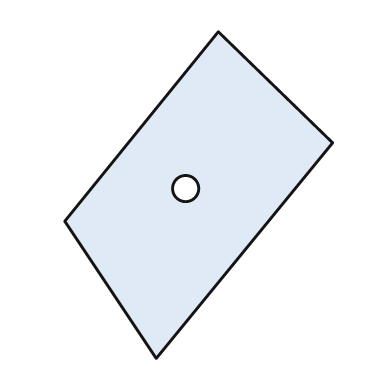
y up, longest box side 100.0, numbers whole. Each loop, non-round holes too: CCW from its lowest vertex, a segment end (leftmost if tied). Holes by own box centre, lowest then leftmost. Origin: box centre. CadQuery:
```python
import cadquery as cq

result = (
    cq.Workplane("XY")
    .moveTo(-13.0, -50.0)
    .lineTo(41.0, 16.0)
    .lineTo(6.0, 50.0)
    .lineTo(-41.0, -8.0)
    .close()
    .moveTo(-4.0, 2.0)
    .circle(4.0)
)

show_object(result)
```